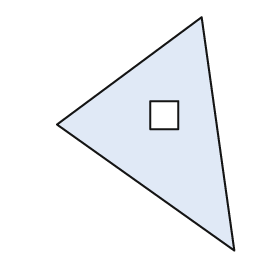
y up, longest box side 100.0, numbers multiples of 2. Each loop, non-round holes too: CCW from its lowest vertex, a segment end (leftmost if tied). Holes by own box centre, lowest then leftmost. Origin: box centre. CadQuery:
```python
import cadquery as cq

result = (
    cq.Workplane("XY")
    .moveTo(38.0, -50.0)
    .lineTo(24.0, 50.0)
    .lineTo(-38.0, 4.0)
    .close()
    .moveTo(2.0, 2.0)
    .lineTo(14.0, 2.0)
    .lineTo(14.0, 14.0)
    .lineTo(2.0, 14.0)
    .close()
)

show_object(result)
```